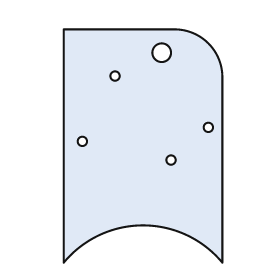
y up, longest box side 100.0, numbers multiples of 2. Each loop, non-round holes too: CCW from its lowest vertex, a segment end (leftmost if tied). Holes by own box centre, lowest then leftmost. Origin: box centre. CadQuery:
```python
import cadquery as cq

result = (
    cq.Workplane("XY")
    .moveTo(-34.0, -50.0)
    .threePointArc((0.0, -34.0), (34.0, -50.0))
    .lineTo(34.0, 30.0)
    .threePointArc((28.0, 44.0), (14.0, 50.0))
    .lineTo(-34.0, 50.0)
    .close()
    .moveTo(12.0, -6.0)
    .circle(2.0)
    .moveTo(-26.0, 2.0)
    .circle(2.0)
    .moveTo(28.0, 8.0)
    .circle(2.0)
    .moveTo(-12.0, 30.0)
    .circle(2.0)
    .moveTo(8.0, 40.0)
    .circle(4.0)
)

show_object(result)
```